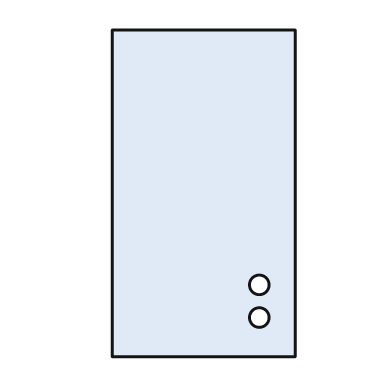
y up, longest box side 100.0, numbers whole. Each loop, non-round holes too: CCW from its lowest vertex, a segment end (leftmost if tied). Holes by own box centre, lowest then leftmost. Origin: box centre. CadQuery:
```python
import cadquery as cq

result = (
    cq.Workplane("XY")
    .moveTo(-28.0, -50.0)
    .lineTo(28.0, -50.0)
    .lineTo(28.0, 50.0)
    .lineTo(-28.0, 50.0)
    .close()
    .moveTo(17.0, -38.0)
    .circle(3.0)
    .moveTo(17.0, -28.0)
    .circle(3.0)
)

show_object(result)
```